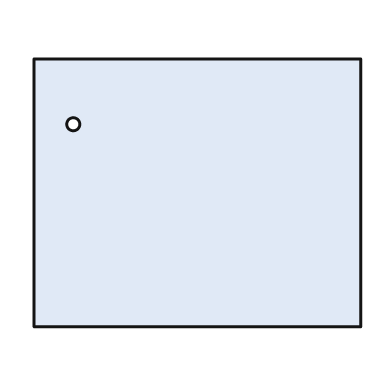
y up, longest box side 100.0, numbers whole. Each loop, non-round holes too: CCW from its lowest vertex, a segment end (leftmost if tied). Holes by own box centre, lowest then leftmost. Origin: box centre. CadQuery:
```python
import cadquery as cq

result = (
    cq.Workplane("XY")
    .moveTo(-50.0, -41.0)
    .lineTo(50.0, -41.0)
    .lineTo(50.0, 41.0)
    .lineTo(-50.0, 41.0)
    .close()
    .moveTo(-38.0, 21.0)
    .circle(2.0)
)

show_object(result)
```